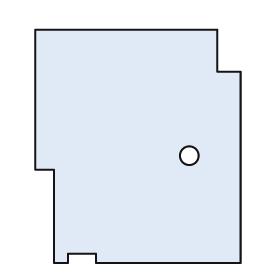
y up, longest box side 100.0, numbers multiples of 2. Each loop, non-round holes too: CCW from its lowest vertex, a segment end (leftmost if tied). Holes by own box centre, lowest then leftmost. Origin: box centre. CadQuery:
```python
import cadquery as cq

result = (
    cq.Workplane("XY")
    .moveTo(-36.0, -50.0)
    .lineTo(-30.0, -50.0)
    .lineTo(-30.0, -46.0)
    .lineTo(-18.0, -46.0)
    .lineTo(-18.0, -50.0)
    .lineTo(44.0, -50.0)
    .lineTo(44.0, 32.0)
    .lineTo(34.0, 32.0)
    .lineTo(34.0, 50.0)
    .lineTo(-44.0, 50.0)
    .lineTo(-44.0, -10.0)
    .lineTo(-36.0, -10.0)
    .close()
    .moveTo(22.0, -4.0)
    .circle(4.0)
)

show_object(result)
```